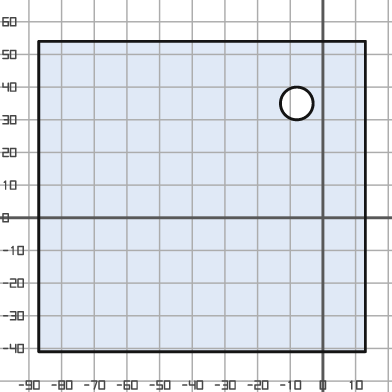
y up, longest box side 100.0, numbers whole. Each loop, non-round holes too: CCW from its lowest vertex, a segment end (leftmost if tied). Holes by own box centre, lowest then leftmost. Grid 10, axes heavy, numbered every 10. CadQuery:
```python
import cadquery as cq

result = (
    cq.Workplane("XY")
    .moveTo(-87.0, -41.0)
    .lineTo(13.0, -41.0)
    .lineTo(13.0, 54.0)
    .lineTo(-87.0, 54.0)
    .close()
    .moveTo(-8.0, 35.0)
    .circle(5.0)
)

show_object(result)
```